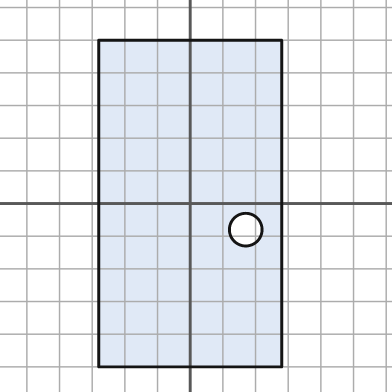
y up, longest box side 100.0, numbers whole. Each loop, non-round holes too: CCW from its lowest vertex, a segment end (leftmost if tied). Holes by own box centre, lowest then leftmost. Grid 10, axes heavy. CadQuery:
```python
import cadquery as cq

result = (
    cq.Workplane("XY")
    .moveTo(-28.0, -50.0)
    .lineTo(28.0, -50.0)
    .lineTo(28.0, 50.0)
    .lineTo(-28.0, 50.0)
    .close()
    .moveTo(17.0, -8.0)
    .circle(5.0)
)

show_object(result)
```